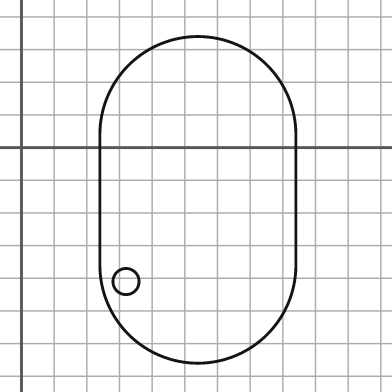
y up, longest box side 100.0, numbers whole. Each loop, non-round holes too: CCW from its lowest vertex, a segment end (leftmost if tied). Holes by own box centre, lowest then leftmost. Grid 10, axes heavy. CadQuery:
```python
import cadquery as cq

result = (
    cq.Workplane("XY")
    .moveTo(24.0, -36.0)
    .threePointArc((54.0, -66.0), (84.0, -36.0))
    .lineTo(84.0, 4.0)
    .threePointArc((54.0, 34.0), (24.0, 4.0))
    .close()
    .moveTo(32.0, -41.0)
    .circle(4.0)
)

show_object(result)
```